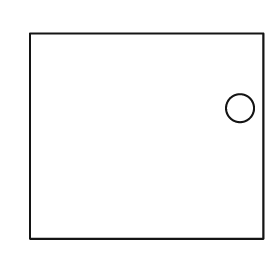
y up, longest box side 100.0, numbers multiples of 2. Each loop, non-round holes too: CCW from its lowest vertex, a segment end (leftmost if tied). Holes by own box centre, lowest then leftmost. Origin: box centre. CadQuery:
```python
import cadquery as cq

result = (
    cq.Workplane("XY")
    .moveTo(-50.0, -44.0)
    .lineTo(50.0, -44.0)
    .lineTo(50.0, 44.0)
    .lineTo(-50.0, 44.0)
    .close()
    .moveTo(40.0, 12.0)
    .circle(6.0)
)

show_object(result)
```